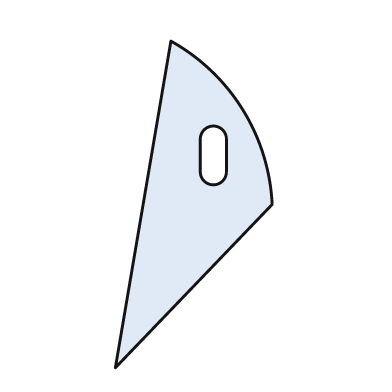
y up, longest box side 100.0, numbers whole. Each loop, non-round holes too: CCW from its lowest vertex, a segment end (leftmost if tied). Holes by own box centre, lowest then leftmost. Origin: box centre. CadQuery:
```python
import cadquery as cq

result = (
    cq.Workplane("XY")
    .moveTo(-24.0, -50.0)
    .lineTo(24.0, 0.0)
    .threePointArc((15.0, 29.0), (-7.0, 50.0))
    .close()
    .moveTo(2.0, 10.0)
    .threePointArc((6.0, 6.0), (10.0, 10.0))
    .lineTo(10.0, 20.0)
    .threePointArc((6.0, 24.0), (2.0, 20.0))
    .close()
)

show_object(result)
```